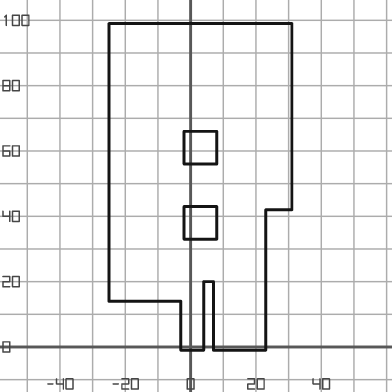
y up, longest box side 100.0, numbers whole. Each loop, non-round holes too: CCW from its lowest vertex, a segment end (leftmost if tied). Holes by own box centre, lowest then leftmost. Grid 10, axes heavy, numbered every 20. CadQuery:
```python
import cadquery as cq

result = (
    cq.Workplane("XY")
    .moveTo(-3.0, -1.0)
    .lineTo(4.0, -1.0)
    .lineTo(4.0, 20.0)
    .lineTo(7.0, 20.0)
    .lineTo(7.0, -1.0)
    .lineTo(23.0, -1.0)
    .lineTo(23.0, 42.0)
    .lineTo(31.0, 42.0)
    .lineTo(31.0, 99.0)
    .lineTo(-25.0, 99.0)
    .lineTo(-25.0, 14.0)
    .lineTo(-3.0, 14.0)
    .close()
    .moveTo(-2.0, 33.0)
    .lineTo(8.0, 33.0)
    .lineTo(8.0, 43.0)
    .lineTo(-2.0, 43.0)
    .close()
    .moveTo(-2.0, 56.0)
    .lineTo(8.0, 56.0)
    .lineTo(8.0, 66.0)
    .lineTo(-2.0, 66.0)
    .close()
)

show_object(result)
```